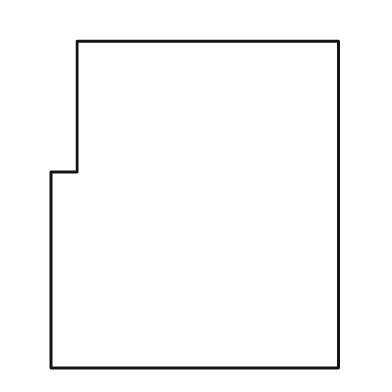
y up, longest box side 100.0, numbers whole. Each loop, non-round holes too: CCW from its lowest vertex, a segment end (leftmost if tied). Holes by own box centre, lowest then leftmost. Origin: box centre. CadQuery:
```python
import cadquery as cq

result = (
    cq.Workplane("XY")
    .moveTo(-44.0, -50.0)
    .lineTo(44.0, -50.0)
    .lineTo(44.0, 50.0)
    .lineTo(-36.0, 50.0)
    .lineTo(-36.0, 10.0)
    .lineTo(-44.0, 10.0)
    .close()
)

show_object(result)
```